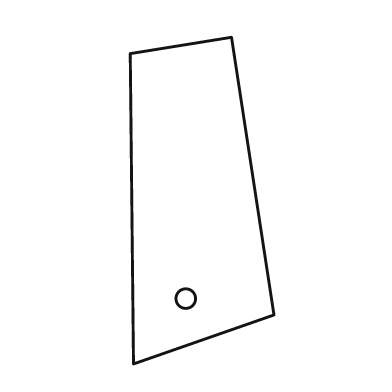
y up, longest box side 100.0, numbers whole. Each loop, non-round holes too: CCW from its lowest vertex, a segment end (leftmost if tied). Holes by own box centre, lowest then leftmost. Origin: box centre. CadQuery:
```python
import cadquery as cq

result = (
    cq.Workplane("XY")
    .moveTo(-21.0, -50.0)
    .lineTo(22.0, -35.0)
    .lineTo(9.0, 50.0)
    .lineTo(-22.0, 45.0)
    .close()
    .moveTo(-5.0, -30.0)
    .circle(3.0)
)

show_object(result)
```